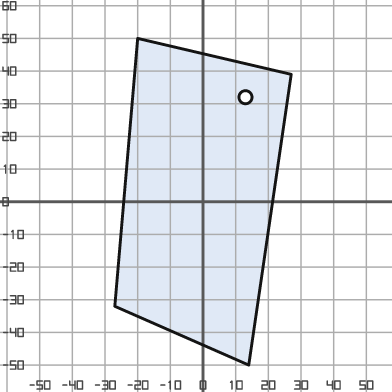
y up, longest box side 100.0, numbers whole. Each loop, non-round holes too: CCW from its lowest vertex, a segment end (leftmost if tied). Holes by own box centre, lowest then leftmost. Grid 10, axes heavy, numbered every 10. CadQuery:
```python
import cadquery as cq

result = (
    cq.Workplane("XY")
    .moveTo(14.0, -50.0)
    .lineTo(27.0, 39.0)
    .lineTo(-20.0, 50.0)
    .lineTo(-27.0, -32.0)
    .close()
    .moveTo(13.0, 32.0)
    .circle(2.0)
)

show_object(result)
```